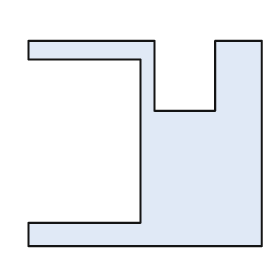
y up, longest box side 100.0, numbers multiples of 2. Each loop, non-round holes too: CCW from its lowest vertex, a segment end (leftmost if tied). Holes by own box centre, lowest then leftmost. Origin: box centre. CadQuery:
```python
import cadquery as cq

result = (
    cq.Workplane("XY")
    .moveTo(-50.0, -44.0)
    .lineTo(50.0, -44.0)
    .lineTo(50.0, 44.0)
    .lineTo(30.0, 44.0)
    .lineTo(30.0, 14.0)
    .lineTo(4.0, 14.0)
    .lineTo(4.0, 44.0)
    .lineTo(-50.0, 44.0)
    .lineTo(-50.0, 36.0)
    .lineTo(-2.0, 36.0)
    .lineTo(-2.0, -34.0)
    .lineTo(-50.0, -34.0)
    .close()
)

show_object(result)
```